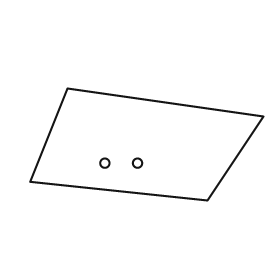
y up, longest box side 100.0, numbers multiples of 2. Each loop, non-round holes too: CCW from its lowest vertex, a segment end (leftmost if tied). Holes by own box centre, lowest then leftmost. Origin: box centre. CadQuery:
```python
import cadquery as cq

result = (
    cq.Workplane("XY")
    .moveTo(26.0, -24.0)
    .lineTo(50.0, 12.0)
    .lineTo(-34.0, 24.0)
    .lineTo(-50.0, -16.0)
    .close()
    .moveTo(-18.0, -8.0)
    .circle(2.0)
    .moveTo(-4.0, -8.0)
    .circle(2.0)
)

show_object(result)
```